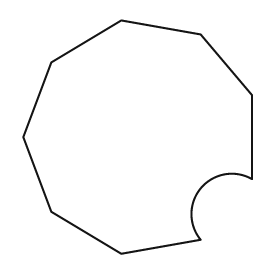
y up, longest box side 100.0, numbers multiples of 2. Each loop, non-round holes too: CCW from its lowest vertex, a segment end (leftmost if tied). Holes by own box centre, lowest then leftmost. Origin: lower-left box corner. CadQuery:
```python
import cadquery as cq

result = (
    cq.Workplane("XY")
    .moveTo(42.0, 0.0)
    .lineTo(76.0, 6.0)
    .threePointArc((76.0, 28.0), (98.0, 32.0))
    .lineTo(98.0, 68.0)
    .lineTo(76.0, 94.0)
    .lineTo(42.0, 100.0)
    .lineTo(12.0, 82.0)
    .lineTo(0.0, 50.0)
    .lineTo(12.0, 18.0)
    .close()
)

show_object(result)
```